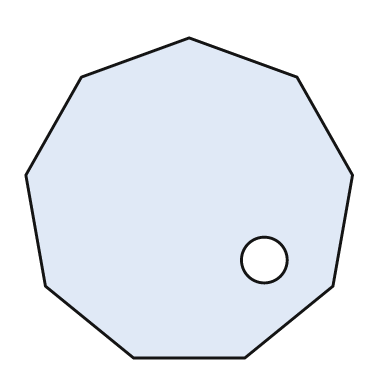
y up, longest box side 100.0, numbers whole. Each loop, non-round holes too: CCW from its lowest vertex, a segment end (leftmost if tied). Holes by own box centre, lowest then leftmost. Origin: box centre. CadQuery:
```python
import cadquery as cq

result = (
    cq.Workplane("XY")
    .moveTo(-17.0, -49.0)
    .lineTo(17.0, -49.0)
    .lineTo(44.0, -27.0)
    .lineTo(50.0, 7.0)
    .lineTo(33.0, 37.0)
    .lineTo(0.0, 49.0)
    .lineTo(-33.0, 37.0)
    .lineTo(-50.0, 7.0)
    .lineTo(-44.0, -27.0)
    .close()
    .moveTo(23.0, -19.0)
    .circle(7.0)
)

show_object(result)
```